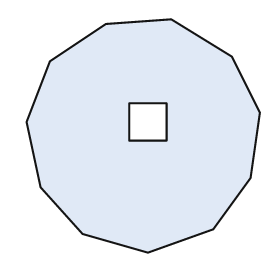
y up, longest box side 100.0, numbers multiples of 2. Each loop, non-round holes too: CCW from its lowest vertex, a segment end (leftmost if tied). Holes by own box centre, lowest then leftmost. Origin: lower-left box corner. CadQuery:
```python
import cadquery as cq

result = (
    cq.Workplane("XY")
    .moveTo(52.0, 0.0)
    .lineTo(80.0, 10.0)
    .lineTo(96.0, 32.0)
    .lineTo(100.0, 60.0)
    .lineTo(88.0, 84.0)
    .lineTo(62.0, 100.0)
    .lineTo(34.0, 98.0)
    .lineTo(10.0, 82.0)
    .lineTo(0.0, 56.0)
    .lineTo(6.0, 28.0)
    .lineTo(24.0, 8.0)
    .close()
    .moveTo(44.0, 48.0)
    .lineTo(60.0, 48.0)
    .lineTo(60.0, 64.0)
    .lineTo(44.0, 64.0)
    .close()
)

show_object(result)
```